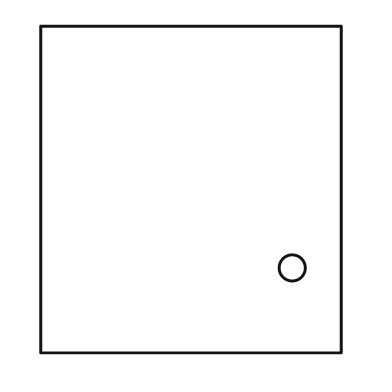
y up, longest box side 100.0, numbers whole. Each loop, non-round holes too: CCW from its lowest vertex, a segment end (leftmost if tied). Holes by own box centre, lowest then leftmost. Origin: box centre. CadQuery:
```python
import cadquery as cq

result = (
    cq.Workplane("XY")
    .moveTo(-46.0, -50.0)
    .lineTo(46.0, -50.0)
    .lineTo(46.0, 50.0)
    .lineTo(-46.0, 50.0)
    .close()
    .moveTo(31.0, -24.0)
    .circle(4.0)
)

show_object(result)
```